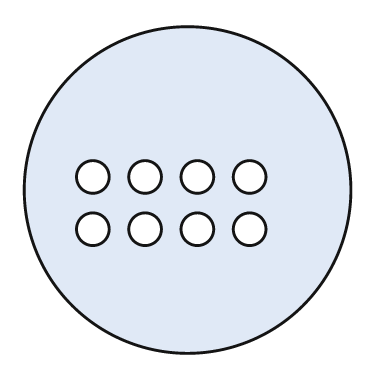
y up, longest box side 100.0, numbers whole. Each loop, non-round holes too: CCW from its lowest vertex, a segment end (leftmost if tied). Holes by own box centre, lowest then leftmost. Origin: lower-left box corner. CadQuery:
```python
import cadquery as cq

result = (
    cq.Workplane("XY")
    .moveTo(50.0, 50.0)
    .circle(50.0)
    .moveTo(21.0, 38.0)
    .circle(5.0)
    .moveTo(37.0, 38.0)
    .circle(5.0)
    .moveTo(53.0, 38.0)
    .circle(5.0)
    .moveTo(69.0, 38.0)
    .circle(5.0)
    .moveTo(21.0, 54.0)
    .circle(5.0)
    .moveTo(37.0, 54.0)
    .circle(5.0)
    .moveTo(53.0, 54.0)
    .circle(5.0)
    .moveTo(69.0, 54.0)
    .circle(5.0)
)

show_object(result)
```